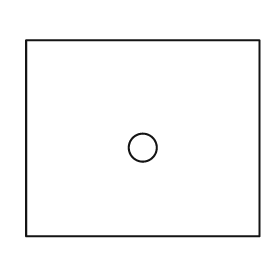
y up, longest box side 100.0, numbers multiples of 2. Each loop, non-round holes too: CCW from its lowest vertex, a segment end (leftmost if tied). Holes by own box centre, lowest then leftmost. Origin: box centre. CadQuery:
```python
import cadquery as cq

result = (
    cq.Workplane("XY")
    .moveTo(-50.0, -42.0)
    .lineTo(50.0, -42.0)
    .lineTo(50.0, 42.0)
    .lineTo(-50.0, 42.0)
    .close()
    .moveTo(0.0, -4.0)
    .circle(6.0)
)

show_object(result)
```